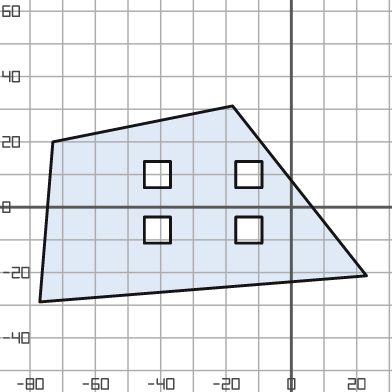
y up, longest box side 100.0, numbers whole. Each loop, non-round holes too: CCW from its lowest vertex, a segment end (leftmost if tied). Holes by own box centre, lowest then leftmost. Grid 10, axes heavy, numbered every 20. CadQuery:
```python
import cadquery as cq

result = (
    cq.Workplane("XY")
    .moveTo(-77.0, -29.0)
    .lineTo(23.0, -21.0)
    .lineTo(-18.0, 31.0)
    .lineTo(-73.0, 20.0)
    .close()
    .moveTo(-45.0, -11.0)
    .lineTo(-37.0, -11.0)
    .lineTo(-37.0, -3.0)
    .lineTo(-45.0, -3.0)
    .close()
    .moveTo(-17.0, -11.0)
    .lineTo(-9.0, -11.0)
    .lineTo(-9.0, -3.0)
    .lineTo(-17.0, -3.0)
    .close()
    .moveTo(-45.0, 6.0)
    .lineTo(-37.0, 6.0)
    .lineTo(-37.0, 14.0)
    .lineTo(-45.0, 14.0)
    .close()
    .moveTo(-17.0, 6.0)
    .lineTo(-9.0, 6.0)
    .lineTo(-9.0, 14.0)
    .lineTo(-17.0, 14.0)
    .close()
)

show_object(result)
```